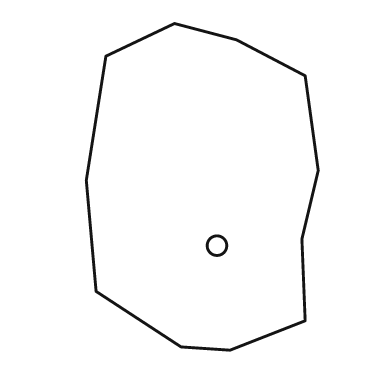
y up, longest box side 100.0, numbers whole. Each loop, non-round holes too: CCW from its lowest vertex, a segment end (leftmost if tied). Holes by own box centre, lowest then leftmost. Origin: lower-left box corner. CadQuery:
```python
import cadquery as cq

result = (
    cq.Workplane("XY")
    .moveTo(44.0, 0.0)
    .lineTo(67.0, 9.0)
    .lineTo(66.0, 34.0)
    .lineTo(71.0, 55.0)
    .lineTo(67.0, 84.0)
    .lineTo(46.0, 95.0)
    .lineTo(27.0, 100.0)
    .lineTo(6.0, 90.0)
    .lineTo(0.0, 52.0)
    .lineTo(3.0, 18.0)
    .lineTo(29.0, 1.0)
    .close()
    .moveTo(40.0, 32.0)
    .circle(3.0)
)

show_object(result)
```